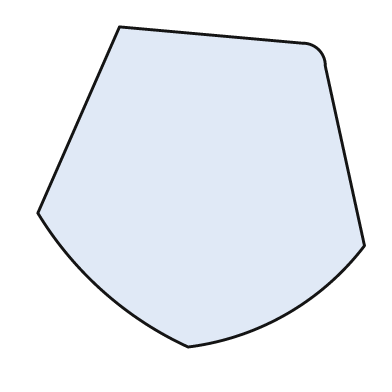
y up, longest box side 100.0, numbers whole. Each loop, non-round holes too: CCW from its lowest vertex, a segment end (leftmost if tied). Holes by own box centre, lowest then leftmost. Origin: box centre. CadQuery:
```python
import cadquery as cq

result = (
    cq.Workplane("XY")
    .moveTo(-4.0, -49.0)
    .threePointArc((26.0, -39.0), (50.0, -18.0))
    .lineTo(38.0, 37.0)
    .threePointArc((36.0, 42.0), (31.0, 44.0))
    .lineTo(-25.0, 49.0)
    .lineTo(-50.0, -8.0)
    .threePointArc((-30.0, -32.0), (-4.0, -49.0))
    .close()
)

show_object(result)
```